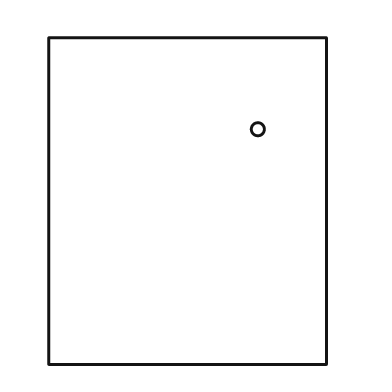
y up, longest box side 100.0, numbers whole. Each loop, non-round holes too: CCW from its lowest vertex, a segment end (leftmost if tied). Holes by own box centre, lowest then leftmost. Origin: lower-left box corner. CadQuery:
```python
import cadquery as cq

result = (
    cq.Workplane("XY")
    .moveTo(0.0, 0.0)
    .lineTo(85.0, 0.0)
    .lineTo(85.0, 100.0)
    .lineTo(0.0, 100.0)
    .close()
    .moveTo(64.0, 72.0)
    .circle(2.0)
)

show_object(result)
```